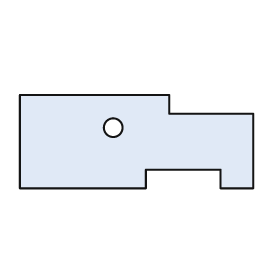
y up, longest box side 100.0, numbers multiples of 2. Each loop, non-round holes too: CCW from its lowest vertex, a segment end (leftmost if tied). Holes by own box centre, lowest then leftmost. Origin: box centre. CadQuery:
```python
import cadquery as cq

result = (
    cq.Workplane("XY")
    .moveTo(-50.0, -20.0)
    .lineTo(4.0, -20.0)
    .lineTo(4.0, -12.0)
    .lineTo(36.0, -12.0)
    .lineTo(36.0, -20.0)
    .lineTo(50.0, -20.0)
    .lineTo(50.0, 12.0)
    .lineTo(14.0, 12.0)
    .lineTo(14.0, 20.0)
    .lineTo(-50.0, 20.0)
    .close()
    .moveTo(-10.0, 6.0)
    .circle(4.0)
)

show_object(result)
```